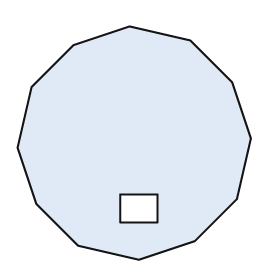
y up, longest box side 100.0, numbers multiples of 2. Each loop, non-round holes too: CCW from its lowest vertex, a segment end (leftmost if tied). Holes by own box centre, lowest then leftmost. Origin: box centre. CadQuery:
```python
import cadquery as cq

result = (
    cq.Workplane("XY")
    .moveTo(2.0, -50.0)
    .lineTo(26.0, -42.0)
    .lineTo(44.0, -24.0)
    .lineTo(50.0, 2.0)
    .lineTo(42.0, 26.0)
    .lineTo(24.0, 44.0)
    .lineTo(-2.0, 50.0)
    .lineTo(-26.0, 42.0)
    .lineTo(-44.0, 24.0)
    .lineTo(-50.0, -2.0)
    .lineTo(-42.0, -26.0)
    .lineTo(-24.0, -44.0)
    .close()
    .moveTo(-6.0, -34.0)
    .lineTo(10.0, -34.0)
    .lineTo(10.0, -22.0)
    .lineTo(-6.0, -22.0)
    .close()
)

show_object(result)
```